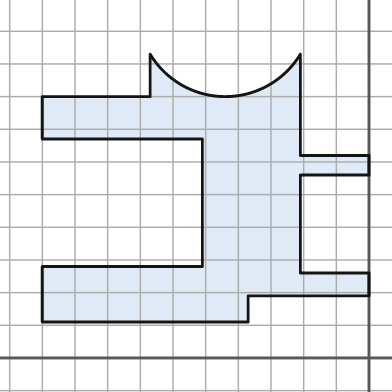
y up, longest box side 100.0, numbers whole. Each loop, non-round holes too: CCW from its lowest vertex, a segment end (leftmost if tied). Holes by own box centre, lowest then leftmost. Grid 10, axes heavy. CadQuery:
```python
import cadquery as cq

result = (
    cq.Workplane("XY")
    .moveTo(-100.0, 11.0)
    .lineTo(-37.0, 11.0)
    .lineTo(-37.0, 19.0)
    .lineTo(0.0, 19.0)
    .lineTo(0.0, 26.0)
    .lineTo(-21.0, 26.0)
    .lineTo(-21.0, 56.0)
    .lineTo(0.0, 56.0)
    .lineTo(0.0, 62.0)
    .lineTo(-21.0, 62.0)
    .lineTo(-21.0, 93.0)
    .threePointArc((-44.0, 80.0), (-67.0, 93.0))
    .lineTo(-67.0, 80.0)
    .lineTo(-100.0, 80.0)
    .lineTo(-100.0, 67.0)
    .lineTo(-51.0, 67.0)
    .lineTo(-51.0, 28.0)
    .lineTo(-100.0, 28.0)
    .close()
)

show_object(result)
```